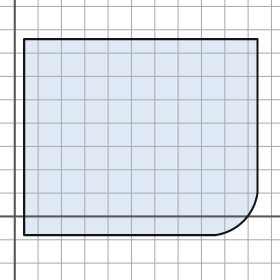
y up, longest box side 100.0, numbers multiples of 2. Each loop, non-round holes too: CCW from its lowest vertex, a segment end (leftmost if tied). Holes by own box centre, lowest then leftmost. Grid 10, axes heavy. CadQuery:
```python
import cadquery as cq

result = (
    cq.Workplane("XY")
    .moveTo(4.0, -8.0)
    .lineTo(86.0, -8.0)
    .threePointArc((98.0, -2.0), (104.0, 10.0))
    .lineTo(104.0, 76.0)
    .lineTo(4.0, 76.0)
    .close()
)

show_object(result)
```